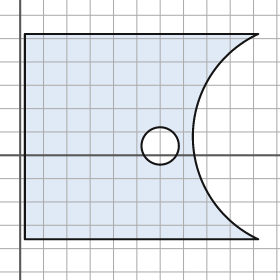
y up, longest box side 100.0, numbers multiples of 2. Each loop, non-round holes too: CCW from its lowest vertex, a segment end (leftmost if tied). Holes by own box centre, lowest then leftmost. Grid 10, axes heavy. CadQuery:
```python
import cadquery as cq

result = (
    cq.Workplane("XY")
    .moveTo(2.0, -36.0)
    .lineTo(102.0, -36.0)
    .threePointArc((74.0, 8.0), (102.0, 52.0))
    .lineTo(2.0, 52.0)
    .close()
    .moveTo(60.0, 4.0)
    .circle(8.0)
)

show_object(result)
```